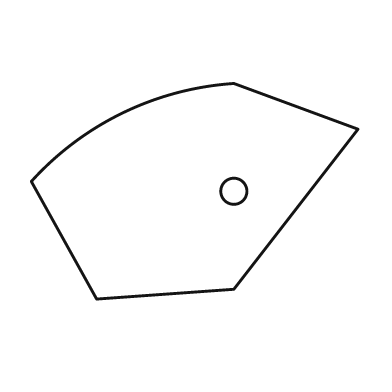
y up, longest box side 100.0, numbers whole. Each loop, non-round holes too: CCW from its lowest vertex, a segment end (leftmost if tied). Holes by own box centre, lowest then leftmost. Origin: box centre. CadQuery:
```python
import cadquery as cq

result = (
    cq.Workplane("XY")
    .moveTo(-30.0, -33.0)
    .lineTo(12.0, -30.0)
    .lineTo(50.0, 19.0)
    .lineTo(12.0, 33.0)
    .threePointArc((-22.0, 24.0), (-50.0, 3.0))
    .close()
    .moveTo(12.0, 0.0)
    .circle(4.0)
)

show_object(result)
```